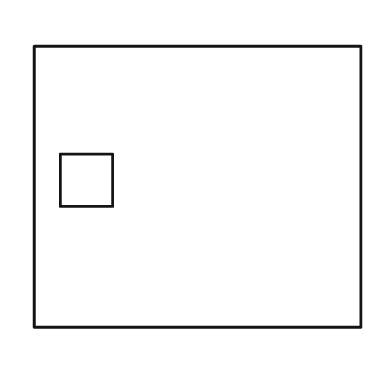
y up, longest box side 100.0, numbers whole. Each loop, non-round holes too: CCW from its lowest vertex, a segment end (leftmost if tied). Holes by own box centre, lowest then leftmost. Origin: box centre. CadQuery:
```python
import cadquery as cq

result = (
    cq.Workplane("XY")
    .moveTo(-50.0, -43.0)
    .lineTo(50.0, -43.0)
    .lineTo(50.0, 43.0)
    .lineTo(-50.0, 43.0)
    .close()
    .moveTo(-42.0, -6.0)
    .lineTo(-26.0, -6.0)
    .lineTo(-26.0, 10.0)
    .lineTo(-42.0, 10.0)
    .close()
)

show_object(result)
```